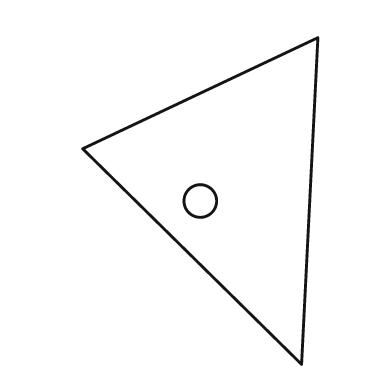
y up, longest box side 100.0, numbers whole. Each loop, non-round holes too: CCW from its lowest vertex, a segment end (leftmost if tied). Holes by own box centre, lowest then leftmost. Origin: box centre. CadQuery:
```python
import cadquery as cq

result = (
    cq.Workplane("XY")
    .moveTo(31.0, -50.0)
    .lineTo(36.0, 50.0)
    .lineTo(-36.0, 16.0)
    .close()
    .moveTo(0.0, 0.0)
    .circle(5.0)
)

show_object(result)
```